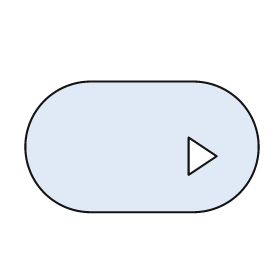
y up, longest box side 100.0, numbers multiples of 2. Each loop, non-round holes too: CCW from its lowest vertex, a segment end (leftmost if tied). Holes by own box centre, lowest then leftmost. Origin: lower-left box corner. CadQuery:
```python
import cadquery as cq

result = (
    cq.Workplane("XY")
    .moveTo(28.0, 0.0)
    .lineTo(72.0, 0.0)
    .threePointArc((100.0, 28.0), (72.0, 56.0))
    .lineTo(28.0, 56.0)
    .threePointArc((0.0, 28.0), (28.0, 0.0))
    .close()
    .moveTo(70.0, 16.0)
    .lineTo(82.0, 24.0)
    .lineTo(70.0, 32.0)
    .close()
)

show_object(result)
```